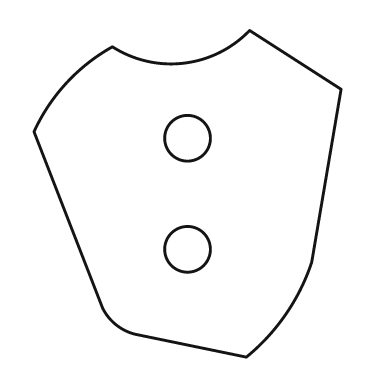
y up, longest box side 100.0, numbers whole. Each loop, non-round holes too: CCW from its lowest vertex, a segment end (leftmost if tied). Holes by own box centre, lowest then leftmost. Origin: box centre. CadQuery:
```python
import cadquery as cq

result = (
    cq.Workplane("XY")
    .moveTo(18.0, -50.0)
    .threePointArc((30.0, -37.0), (38.0, -21.0))
    .lineTo(47.0, 32.0)
    .lineTo(19.0, 50.0)
    .threePointArc((-1.0, 40.0), (-23.0, 45.0))
    .threePointArc((-37.0, 34.0), (-47.0, 19.0))
    .lineTo(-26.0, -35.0)
    .threePointArc((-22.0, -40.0), (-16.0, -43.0))
    .close()
    .moveTo(0.0, -17.0)
    .circle(7.0)
    .moveTo(0.0, 17.0)
    .circle(7.0)
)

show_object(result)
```